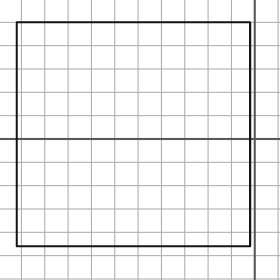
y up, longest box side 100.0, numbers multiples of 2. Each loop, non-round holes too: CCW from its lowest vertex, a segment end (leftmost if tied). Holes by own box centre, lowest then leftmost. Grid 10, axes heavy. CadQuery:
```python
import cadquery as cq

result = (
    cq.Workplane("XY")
    .moveTo(-102.0, -46.0)
    .lineTo(-2.0, -46.0)
    .lineTo(-2.0, 50.0)
    .lineTo(-102.0, 50.0)
    .close()
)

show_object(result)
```